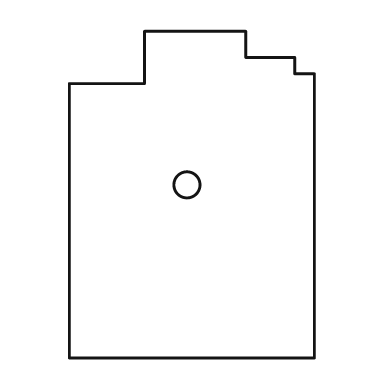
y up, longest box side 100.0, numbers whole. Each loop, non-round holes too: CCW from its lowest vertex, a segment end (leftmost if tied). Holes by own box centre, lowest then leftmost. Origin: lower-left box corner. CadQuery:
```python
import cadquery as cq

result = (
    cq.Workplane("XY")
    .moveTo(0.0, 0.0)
    .lineTo(75.0, 0.0)
    .lineTo(75.0, 87.0)
    .lineTo(69.0, 87.0)
    .lineTo(69.0, 92.0)
    .lineTo(54.0, 92.0)
    .lineTo(54.0, 100.0)
    .lineTo(23.0, 100.0)
    .lineTo(23.0, 84.0)
    .lineTo(0.0, 84.0)
    .close()
    .moveTo(36.0, 53.0)
    .circle(4.0)
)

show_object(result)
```